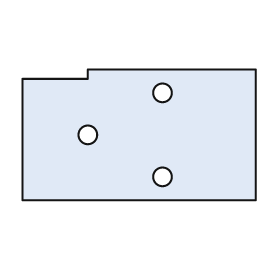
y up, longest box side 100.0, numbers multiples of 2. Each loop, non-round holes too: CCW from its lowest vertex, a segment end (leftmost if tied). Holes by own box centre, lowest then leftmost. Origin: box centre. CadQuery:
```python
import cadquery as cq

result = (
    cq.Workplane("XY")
    .moveTo(-50.0, -28.0)
    .lineTo(50.0, -28.0)
    .lineTo(50.0, 28.0)
    .lineTo(-22.0, 28.0)
    .lineTo(-22.0, 24.0)
    .lineTo(-50.0, 24.0)
    .close()
    .moveTo(10.0, -18.0)
    .circle(4.0)
    .moveTo(-22.0, 0.0)
    .circle(4.0)
    .moveTo(10.0, 18.0)
    .circle(4.0)
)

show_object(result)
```